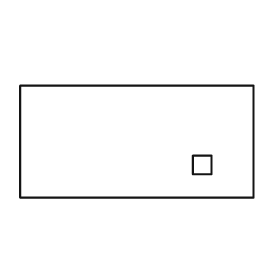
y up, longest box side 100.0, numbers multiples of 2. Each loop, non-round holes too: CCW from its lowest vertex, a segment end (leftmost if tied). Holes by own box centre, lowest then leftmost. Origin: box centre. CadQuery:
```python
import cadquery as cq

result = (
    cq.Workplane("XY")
    .moveTo(-50.0, -24.0)
    .lineTo(50.0, -24.0)
    .lineTo(50.0, 24.0)
    .lineTo(-50.0, 24.0)
    .close()
    .moveTo(24.0, -14.0)
    .lineTo(32.0, -14.0)
    .lineTo(32.0, -6.0)
    .lineTo(24.0, -6.0)
    .close()
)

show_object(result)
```